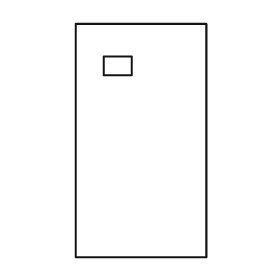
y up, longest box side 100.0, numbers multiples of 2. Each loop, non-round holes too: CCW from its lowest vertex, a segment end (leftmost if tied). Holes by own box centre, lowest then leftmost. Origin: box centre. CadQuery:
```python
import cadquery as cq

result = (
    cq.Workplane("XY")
    .moveTo(-28.0, -50.0)
    .lineTo(28.0, -50.0)
    .lineTo(28.0, 50.0)
    .lineTo(-28.0, 50.0)
    .close()
    .moveTo(-16.0, 28.0)
    .lineTo(-4.0, 28.0)
    .lineTo(-4.0, 36.0)
    .lineTo(-16.0, 36.0)
    .close()
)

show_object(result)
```